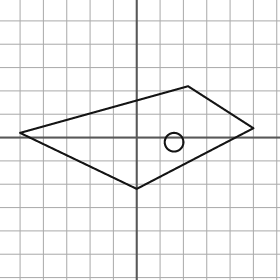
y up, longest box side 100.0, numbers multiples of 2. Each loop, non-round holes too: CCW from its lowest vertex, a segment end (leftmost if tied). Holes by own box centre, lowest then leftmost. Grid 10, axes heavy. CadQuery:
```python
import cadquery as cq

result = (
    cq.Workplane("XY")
    .moveTo(0.0, -22.0)
    .lineTo(50.0, 4.0)
    .lineTo(22.0, 22.0)
    .lineTo(-50.0, 2.0)
    .close()
    .moveTo(16.0, -2.0)
    .circle(4.0)
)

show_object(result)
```